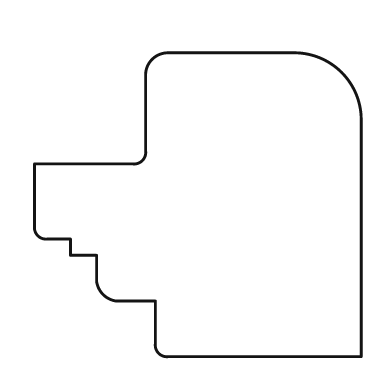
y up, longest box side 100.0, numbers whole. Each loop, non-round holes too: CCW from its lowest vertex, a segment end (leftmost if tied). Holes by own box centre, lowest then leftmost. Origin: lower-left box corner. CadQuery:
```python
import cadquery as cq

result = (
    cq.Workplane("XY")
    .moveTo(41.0, 0.0)
    .lineTo(100.0, 0.0)
    .lineTo(100.0, 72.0)
    .threePointArc((94.0, 87.0), (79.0, 93.0))
    .lineTo(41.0, 93.0)
    .threePointArc((36.0, 91.0), (34.0, 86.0))
    .lineTo(34.0, 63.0)
    .threePointArc((33.0, 60.0), (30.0, 59.0))
    .lineTo(0.0, 59.0)
    .lineTo(0.0, 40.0)
    .threePointArc((1.0, 37.0), (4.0, 36.0))
    .lineTo(11.0, 36.0)
    .lineTo(11.0, 31.0)
    .lineTo(19.0, 31.0)
    .lineTo(19.0, 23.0)
    .threePointArc((21.0, 19.0), (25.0, 17.0))
    .lineTo(37.0, 17.0)
    .lineTo(37.0, 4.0)
    .threePointArc((38.0, 1.0), (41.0, 0.0))
    .close()
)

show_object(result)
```